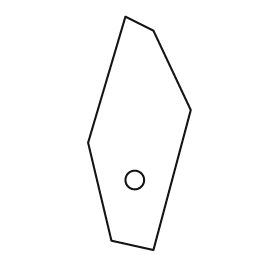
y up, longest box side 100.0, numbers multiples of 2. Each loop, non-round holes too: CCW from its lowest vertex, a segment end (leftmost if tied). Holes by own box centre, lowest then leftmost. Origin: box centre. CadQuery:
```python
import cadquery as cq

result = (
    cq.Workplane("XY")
    .moveTo(6.0, -50.0)
    .lineTo(22.0, 10.0)
    .lineTo(6.0, 44.0)
    .lineTo(-6.0, 50.0)
    .lineTo(-22.0, -4.0)
    .lineTo(-12.0, -46.0)
    .close()
    .moveTo(-2.0, -20.0)
    .circle(4.0)
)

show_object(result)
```